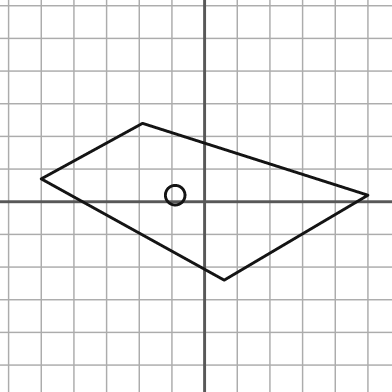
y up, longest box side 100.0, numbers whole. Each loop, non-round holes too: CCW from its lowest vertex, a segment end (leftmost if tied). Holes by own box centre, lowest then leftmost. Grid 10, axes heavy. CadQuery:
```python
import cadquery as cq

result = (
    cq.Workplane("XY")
    .moveTo(6.0, -24.0)
    .lineTo(50.0, 2.0)
    .lineTo(-19.0, 24.0)
    .lineTo(-50.0, 7.0)
    .close()
    .moveTo(-9.0, 2.0)
    .circle(3.0)
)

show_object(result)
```